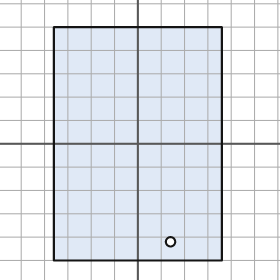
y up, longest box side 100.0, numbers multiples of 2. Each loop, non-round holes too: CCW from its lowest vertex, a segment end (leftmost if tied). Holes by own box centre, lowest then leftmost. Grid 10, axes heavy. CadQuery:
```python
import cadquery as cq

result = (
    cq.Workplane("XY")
    .moveTo(-36.0, -50.0)
    .lineTo(36.0, -50.0)
    .lineTo(36.0, 50.0)
    .lineTo(-36.0, 50.0)
    .close()
    .moveTo(14.0, -42.0)
    .circle(2.0)
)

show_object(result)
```